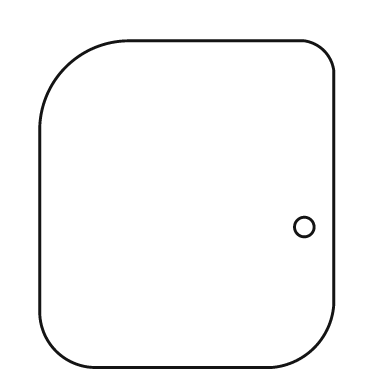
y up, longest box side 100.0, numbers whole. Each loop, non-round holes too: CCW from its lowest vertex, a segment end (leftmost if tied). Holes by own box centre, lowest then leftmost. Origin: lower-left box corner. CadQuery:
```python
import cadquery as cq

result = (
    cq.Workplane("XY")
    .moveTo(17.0, 0.0)
    .lineTo(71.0, 0.0)
    .threePointArc((84.0, 6.0), (90.0, 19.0))
    .lineTo(90.0, 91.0)
    .threePointArc((87.0, 97.0), (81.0, 100.0))
    .lineTo(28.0, 100.0)
    .threePointArc((8.0, 92.0), (0.0, 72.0))
    .lineTo(0.0, 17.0)
    .threePointArc((5.0, 5.0), (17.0, 0.0))
    .close()
    .moveTo(81.0, 43.0)
    .circle(3.0)
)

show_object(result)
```